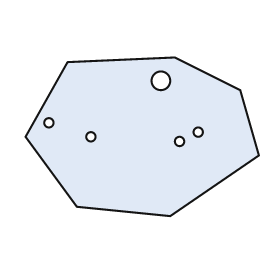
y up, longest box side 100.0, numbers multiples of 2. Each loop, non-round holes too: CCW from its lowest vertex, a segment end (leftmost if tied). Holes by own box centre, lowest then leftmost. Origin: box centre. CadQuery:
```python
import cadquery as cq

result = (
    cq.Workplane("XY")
    .moveTo(12.0, -34.0)
    .lineTo(50.0, -8.0)
    .lineTo(42.0, 20.0)
    .lineTo(14.0, 34.0)
    .lineTo(-32.0, 32.0)
    .lineTo(-50.0, 0.0)
    .lineTo(-28.0, -30.0)
    .close()
    .moveTo(16.0, -2.0)
    .circle(2.0)
    .moveTo(-22.0, 0.0)
    .circle(2.0)
    .moveTo(24.0, 2.0)
    .circle(2.0)
    .moveTo(-40.0, 6.0)
    .circle(2.0)
    .moveTo(8.0, 24.0)
    .circle(4.0)
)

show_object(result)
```